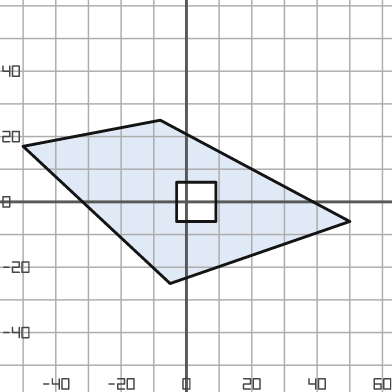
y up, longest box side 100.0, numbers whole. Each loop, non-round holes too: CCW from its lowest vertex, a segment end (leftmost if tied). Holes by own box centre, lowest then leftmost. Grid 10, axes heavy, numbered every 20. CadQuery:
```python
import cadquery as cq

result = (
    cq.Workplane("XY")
    .moveTo(-5.0, -25.0)
    .lineTo(50.0, -6.0)
    .lineTo(-8.0, 25.0)
    .lineTo(-50.0, 17.0)
    .close()
    .moveTo(-3.0, -6.0)
    .lineTo(9.0, -6.0)
    .lineTo(9.0, 6.0)
    .lineTo(-3.0, 6.0)
    .close()
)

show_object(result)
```